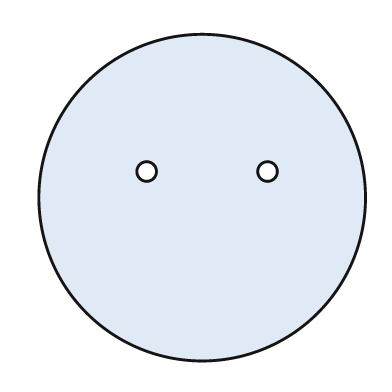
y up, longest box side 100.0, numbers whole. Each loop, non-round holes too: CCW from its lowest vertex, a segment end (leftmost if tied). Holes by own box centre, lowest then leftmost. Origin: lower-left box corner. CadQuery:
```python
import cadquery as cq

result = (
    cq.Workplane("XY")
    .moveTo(50.0, 50.0)
    .circle(50.0)
    .moveTo(33.0, 58.0)
    .circle(3.0)
    .moveTo(70.0, 58.0)
    .circle(3.0)
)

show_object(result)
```